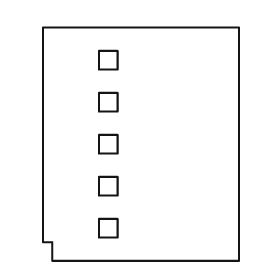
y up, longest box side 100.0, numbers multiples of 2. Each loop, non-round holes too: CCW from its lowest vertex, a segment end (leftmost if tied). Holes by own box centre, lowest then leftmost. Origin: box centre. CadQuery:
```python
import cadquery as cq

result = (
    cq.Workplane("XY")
    .moveTo(-38.0, -50.0)
    .lineTo(42.0, -50.0)
    .lineTo(42.0, 50.0)
    .lineTo(-42.0, 50.0)
    .lineTo(-42.0, -42.0)
    .lineTo(-38.0, -42.0)
    .close()
    .moveTo(-18.0, -40.0)
    .lineTo(-10.0, -40.0)
    .lineTo(-10.0, -32.0)
    .lineTo(-18.0, -32.0)
    .close()
    .moveTo(-18.0, -22.0)
    .lineTo(-10.0, -22.0)
    .lineTo(-10.0, -14.0)
    .lineTo(-18.0, -14.0)
    .close()
    .moveTo(-18.0, -4.0)
    .lineTo(-10.0, -4.0)
    .lineTo(-10.0, 4.0)
    .lineTo(-18.0, 4.0)
    .close()
    .moveTo(-18.0, 14.0)
    .lineTo(-10.0, 14.0)
    .lineTo(-10.0, 22.0)
    .lineTo(-18.0, 22.0)
    .close()
    .moveTo(-18.0, 32.0)
    .lineTo(-10.0, 32.0)
    .lineTo(-10.0, 40.0)
    .lineTo(-18.0, 40.0)
    .close()
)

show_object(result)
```